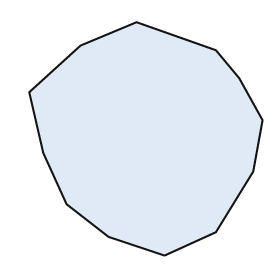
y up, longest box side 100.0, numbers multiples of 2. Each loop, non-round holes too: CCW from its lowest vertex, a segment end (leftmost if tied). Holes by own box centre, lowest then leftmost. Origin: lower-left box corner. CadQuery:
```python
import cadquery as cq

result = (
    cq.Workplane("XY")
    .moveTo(58.0, 0.0)
    .lineTo(80.0, 10.0)
    .lineTo(96.0, 36.0)
    .lineTo(100.0, 58.0)
    .lineTo(90.0, 76.0)
    .lineTo(80.0, 88.0)
    .lineTo(46.0, 100.0)
    .lineTo(22.0, 90.0)
    .lineTo(0.0, 70.0)
    .lineTo(6.0, 44.0)
    .lineTo(16.0, 22.0)
    .lineTo(34.0, 8.0)
    .close()
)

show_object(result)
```